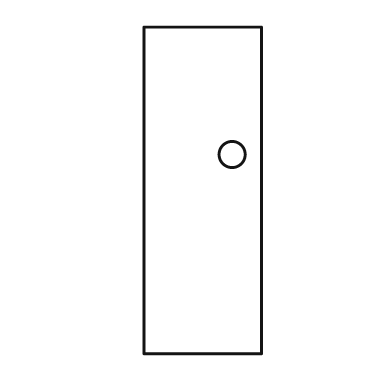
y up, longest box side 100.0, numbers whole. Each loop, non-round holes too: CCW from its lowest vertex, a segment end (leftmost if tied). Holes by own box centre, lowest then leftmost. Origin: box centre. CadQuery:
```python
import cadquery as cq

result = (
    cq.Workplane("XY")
    .moveTo(-18.0, -50.0)
    .lineTo(18.0, -50.0)
    .lineTo(18.0, 50.0)
    .lineTo(-18.0, 50.0)
    .close()
    .moveTo(9.0, 11.0)
    .circle(4.0)
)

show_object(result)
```